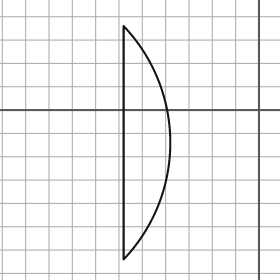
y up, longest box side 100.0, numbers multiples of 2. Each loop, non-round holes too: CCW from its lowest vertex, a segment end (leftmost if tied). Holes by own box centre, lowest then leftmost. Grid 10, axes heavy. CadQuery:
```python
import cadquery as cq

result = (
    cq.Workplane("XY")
    .moveTo(-58.0, -64.0)
    .threePointArc((-38.0, -14.0), (-58.0, 36.0))
    .close()
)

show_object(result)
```